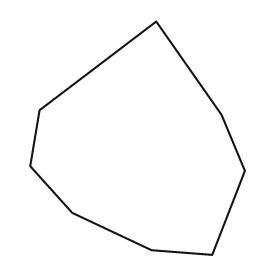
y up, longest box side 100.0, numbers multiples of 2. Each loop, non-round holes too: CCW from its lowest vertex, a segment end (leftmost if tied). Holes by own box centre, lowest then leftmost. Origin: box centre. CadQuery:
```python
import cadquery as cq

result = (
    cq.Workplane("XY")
    .moveTo(32.0, -50.0)
    .lineTo(46.0, -14.0)
    .lineTo(36.0, 10.0)
    .lineTo(8.0, 50.0)
    .lineTo(-42.0, 12.0)
    .lineTo(-46.0, -12.0)
    .lineTo(-28.0, -32.0)
    .lineTo(6.0, -48.0)
    .close()
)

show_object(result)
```